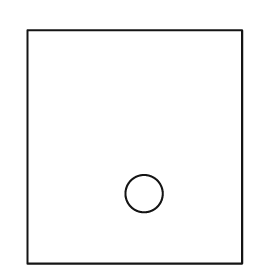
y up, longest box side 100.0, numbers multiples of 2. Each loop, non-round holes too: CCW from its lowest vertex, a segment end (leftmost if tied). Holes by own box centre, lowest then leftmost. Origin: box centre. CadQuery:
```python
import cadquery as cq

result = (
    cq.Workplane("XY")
    .moveTo(-46.0, -50.0)
    .lineTo(46.0, -50.0)
    .lineTo(46.0, 50.0)
    .lineTo(-46.0, 50.0)
    .close()
    .moveTo(4.0, -20.0)
    .circle(8.0)
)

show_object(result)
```